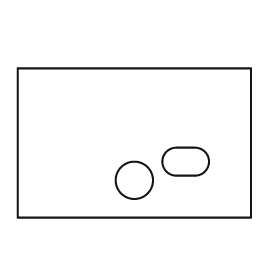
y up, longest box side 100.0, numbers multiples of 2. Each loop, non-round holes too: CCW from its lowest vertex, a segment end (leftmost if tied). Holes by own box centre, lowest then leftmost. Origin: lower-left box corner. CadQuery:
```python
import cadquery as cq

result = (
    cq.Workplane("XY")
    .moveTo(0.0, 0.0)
    .lineTo(100.0, 0.0)
    .lineTo(100.0, 64.0)
    .lineTo(0.0, 64.0)
    .close()
    .moveTo(50.0, 16.0)
    .circle(8.0)
    .moveTo(68.0, 18.0)
    .lineTo(76.0, 18.0)
    .threePointArc((82.0, 24.0), (76.0, 30.0))
    .lineTo(68.0, 30.0)
    .threePointArc((62.0, 24.0), (68.0, 18.0))
    .close()
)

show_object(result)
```